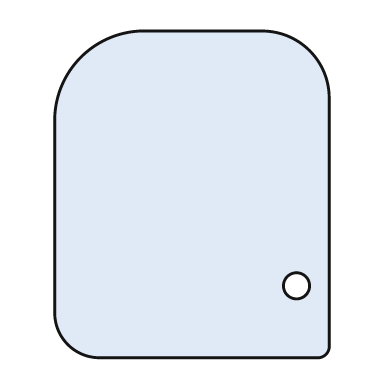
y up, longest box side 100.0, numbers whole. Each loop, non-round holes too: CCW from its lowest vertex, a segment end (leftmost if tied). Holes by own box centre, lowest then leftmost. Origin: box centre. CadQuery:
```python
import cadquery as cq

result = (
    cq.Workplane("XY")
    .moveTo(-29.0, -50.0)
    .lineTo(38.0, -50.0)
    .threePointArc((41.0, -49.0), (42.0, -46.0))
    .lineTo(42.0, 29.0)
    .threePointArc((36.0, 44.0), (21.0, 50.0))
    .lineTo(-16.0, 50.0)
    .threePointArc((-34.0, 42.0), (-42.0, 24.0))
    .lineTo(-42.0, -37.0)
    .threePointArc((-38.0, -46.0), (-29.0, -50.0))
    .close()
    .moveTo(32.0, -28.0)
    .circle(4.0)
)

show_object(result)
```